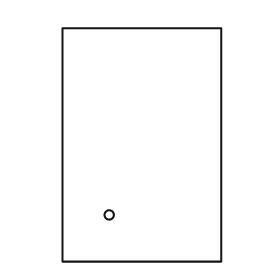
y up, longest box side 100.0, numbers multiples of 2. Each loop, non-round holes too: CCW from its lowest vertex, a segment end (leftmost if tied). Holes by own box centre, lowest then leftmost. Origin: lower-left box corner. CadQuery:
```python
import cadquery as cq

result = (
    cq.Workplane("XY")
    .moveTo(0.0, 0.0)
    .lineTo(68.0, 0.0)
    .lineTo(68.0, 100.0)
    .lineTo(0.0, 100.0)
    .close()
    .moveTo(20.0, 20.0)
    .circle(2.0)
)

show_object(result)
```